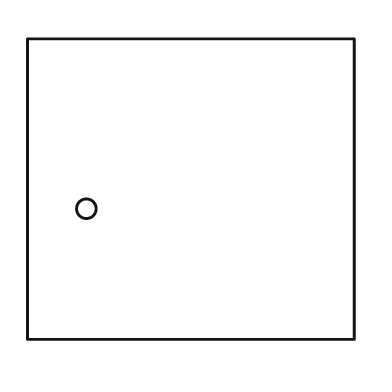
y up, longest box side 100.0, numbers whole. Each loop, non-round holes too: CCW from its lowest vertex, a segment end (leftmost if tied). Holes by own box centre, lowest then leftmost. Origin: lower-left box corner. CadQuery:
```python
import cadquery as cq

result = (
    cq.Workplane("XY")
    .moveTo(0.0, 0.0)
    .lineTo(100.0, 0.0)
    .lineTo(100.0, 92.0)
    .lineTo(0.0, 92.0)
    .close()
    .moveTo(18.0, 40.0)
    .circle(3.0)
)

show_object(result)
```